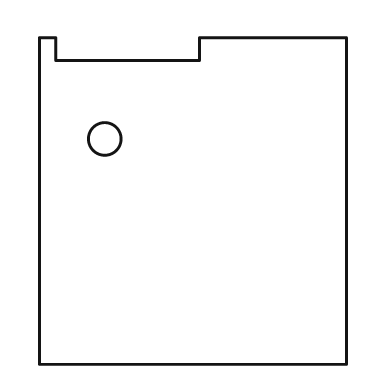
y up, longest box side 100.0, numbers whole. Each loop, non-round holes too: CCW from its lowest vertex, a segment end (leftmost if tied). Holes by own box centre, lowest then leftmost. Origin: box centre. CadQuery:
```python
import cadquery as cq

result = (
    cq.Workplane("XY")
    .moveTo(-47.0, -50.0)
    .lineTo(47.0, -50.0)
    .lineTo(47.0, 50.0)
    .lineTo(2.0, 50.0)
    .lineTo(2.0, 43.0)
    .lineTo(-42.0, 43.0)
    .lineTo(-42.0, 50.0)
    .lineTo(-47.0, 50.0)
    .close()
    .moveTo(-27.0, 19.0)
    .circle(5.0)
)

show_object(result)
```